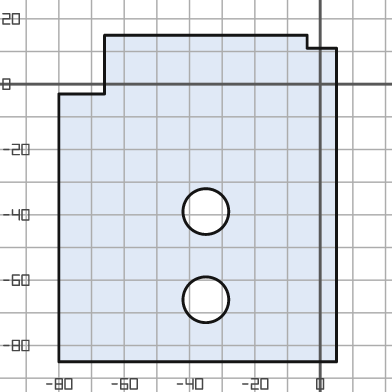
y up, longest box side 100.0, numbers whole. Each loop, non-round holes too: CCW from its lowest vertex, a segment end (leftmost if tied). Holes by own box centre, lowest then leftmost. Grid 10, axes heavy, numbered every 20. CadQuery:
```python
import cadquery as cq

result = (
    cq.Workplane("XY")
    .moveTo(-80.0, -85.0)
    .lineTo(5.0, -85.0)
    .lineTo(5.0, 11.0)
    .lineTo(-4.0, 11.0)
    .lineTo(-4.0, 15.0)
    .lineTo(-66.0, 15.0)
    .lineTo(-66.0, -3.0)
    .lineTo(-80.0, -3.0)
    .close()
    .moveTo(-35.0, -66.0)
    .circle(7.0)
    .moveTo(-35.0, -39.0)
    .circle(7.0)
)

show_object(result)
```